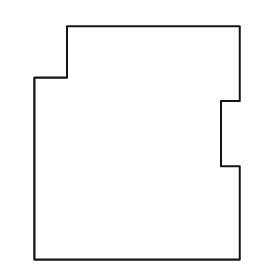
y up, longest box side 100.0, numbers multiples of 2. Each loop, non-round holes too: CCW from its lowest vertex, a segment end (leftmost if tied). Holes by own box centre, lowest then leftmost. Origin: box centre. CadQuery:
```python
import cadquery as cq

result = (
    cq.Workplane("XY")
    .moveTo(-44.0, -50.0)
    .lineTo(44.0, -50.0)
    .lineTo(44.0, -10.0)
    .lineTo(36.0, -10.0)
    .lineTo(36.0, 18.0)
    .lineTo(44.0, 18.0)
    .lineTo(44.0, 50.0)
    .lineTo(-30.0, 50.0)
    .lineTo(-30.0, 28.0)
    .lineTo(-44.0, 28.0)
    .close()
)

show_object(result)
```